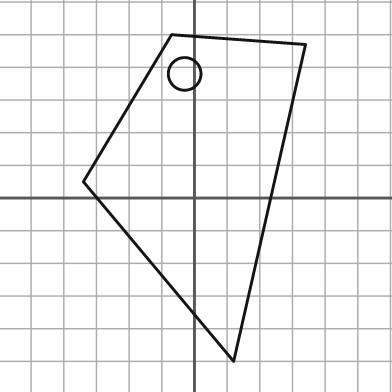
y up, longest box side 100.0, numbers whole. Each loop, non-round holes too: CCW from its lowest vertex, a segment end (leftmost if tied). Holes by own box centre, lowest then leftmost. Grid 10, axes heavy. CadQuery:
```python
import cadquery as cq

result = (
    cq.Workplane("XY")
    .moveTo(12.0, -50.0)
    .lineTo(34.0, 47.0)
    .lineTo(-7.0, 50.0)
    .lineTo(-34.0, 5.0)
    .close()
    .moveTo(-3.0, 38.0)
    .circle(5.0)
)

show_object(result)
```